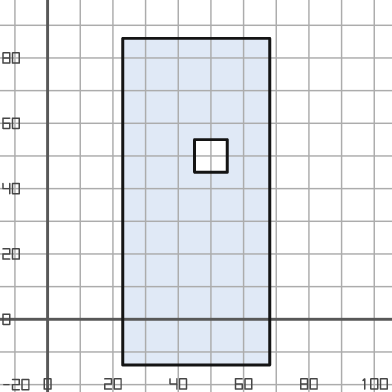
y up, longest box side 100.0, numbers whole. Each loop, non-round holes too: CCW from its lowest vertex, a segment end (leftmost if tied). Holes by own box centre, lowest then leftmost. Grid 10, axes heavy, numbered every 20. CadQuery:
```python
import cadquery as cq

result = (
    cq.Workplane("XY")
    .moveTo(23.0, -14.0)
    .lineTo(68.0, -14.0)
    .lineTo(68.0, 86.0)
    .lineTo(23.0, 86.0)
    .close()
    .moveTo(45.0, 45.0)
    .lineTo(55.0, 45.0)
    .lineTo(55.0, 55.0)
    .lineTo(45.0, 55.0)
    .close()
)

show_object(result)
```